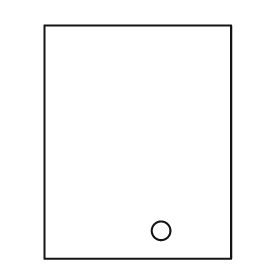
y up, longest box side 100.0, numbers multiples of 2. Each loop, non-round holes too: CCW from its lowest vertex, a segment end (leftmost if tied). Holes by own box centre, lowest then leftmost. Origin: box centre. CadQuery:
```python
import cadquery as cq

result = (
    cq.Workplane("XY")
    .moveTo(-40.0, -50.0)
    .lineTo(40.0, -50.0)
    .lineTo(40.0, 50.0)
    .lineTo(-40.0, 50.0)
    .close()
    .moveTo(10.0, -38.0)
    .circle(4.0)
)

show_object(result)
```